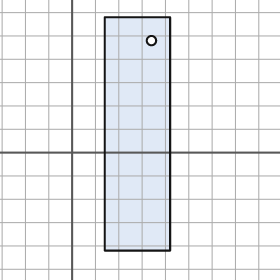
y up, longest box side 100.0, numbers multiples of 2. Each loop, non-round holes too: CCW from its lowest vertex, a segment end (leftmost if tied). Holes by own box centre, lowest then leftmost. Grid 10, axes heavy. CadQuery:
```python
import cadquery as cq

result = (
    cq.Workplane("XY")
    .moveTo(14.0, -42.0)
    .lineTo(42.0, -42.0)
    .lineTo(42.0, 58.0)
    .lineTo(14.0, 58.0)
    .close()
    .moveTo(34.0, 48.0)
    .circle(2.0)
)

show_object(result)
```